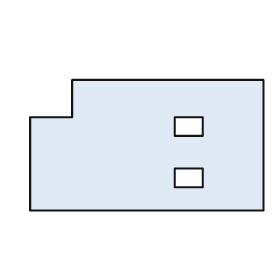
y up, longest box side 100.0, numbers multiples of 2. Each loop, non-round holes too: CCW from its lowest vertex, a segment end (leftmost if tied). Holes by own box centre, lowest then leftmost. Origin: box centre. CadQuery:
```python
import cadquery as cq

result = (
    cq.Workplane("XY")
    .moveTo(-50.0, -28.0)
    .lineTo(50.0, -28.0)
    .lineTo(50.0, 28.0)
    .lineTo(-32.0, 28.0)
    .lineTo(-32.0, 12.0)
    .lineTo(-50.0, 12.0)
    .close()
    .moveTo(12.0, -18.0)
    .lineTo(24.0, -18.0)
    .lineTo(24.0, -10.0)
    .lineTo(12.0, -10.0)
    .close()
    .moveTo(12.0, 4.0)
    .lineTo(24.0, 4.0)
    .lineTo(24.0, 12.0)
    .lineTo(12.0, 12.0)
    .close()
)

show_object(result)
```